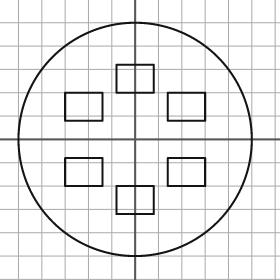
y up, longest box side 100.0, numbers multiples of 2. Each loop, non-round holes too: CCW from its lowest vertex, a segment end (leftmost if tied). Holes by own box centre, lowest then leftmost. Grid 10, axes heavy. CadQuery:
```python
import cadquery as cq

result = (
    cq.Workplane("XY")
    .moveTo(0.0, 0.0)
    .circle(50.0)
    .moveTo(-8.0, -32.0)
    .lineTo(8.0, -32.0)
    .lineTo(8.0, -20.0)
    .lineTo(-8.0, -20.0)
    .close()
    .moveTo(-30.0, -20.0)
    .lineTo(-14.0, -20.0)
    .lineTo(-14.0, -8.0)
    .lineTo(-30.0, -8.0)
    .close()
    .moveTo(14.0, -20.0)
    .lineTo(30.0, -20.0)
    .lineTo(30.0, -8.0)
    .lineTo(14.0, -8.0)
    .close()
    .moveTo(-30.0, 8.0)
    .lineTo(-14.0, 8.0)
    .lineTo(-14.0, 20.0)
    .lineTo(-30.0, 20.0)
    .close()
    .moveTo(14.0, 8.0)
    .lineTo(30.0, 8.0)
    .lineTo(30.0, 20.0)
    .lineTo(14.0, 20.0)
    .close()
    .moveTo(-8.0, 20.0)
    .lineTo(8.0, 20.0)
    .lineTo(8.0, 32.0)
    .lineTo(-8.0, 32.0)
    .close()
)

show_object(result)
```